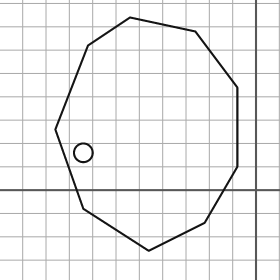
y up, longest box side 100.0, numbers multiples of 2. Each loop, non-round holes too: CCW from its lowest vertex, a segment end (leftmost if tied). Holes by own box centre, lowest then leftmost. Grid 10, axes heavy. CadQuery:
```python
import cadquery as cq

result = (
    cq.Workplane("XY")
    .moveTo(-46.0, -26.0)
    .lineTo(-22.0, -14.0)
    .lineTo(-8.0, 10.0)
    .lineTo(-8.0, 44.0)
    .lineTo(-26.0, 68.0)
    .lineTo(-54.0, 74.0)
    .lineTo(-72.0, 62.0)
    .lineTo(-86.0, 26.0)
    .lineTo(-74.0, -8.0)
    .close()
    .moveTo(-74.0, 16.0)
    .circle(4.0)
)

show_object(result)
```